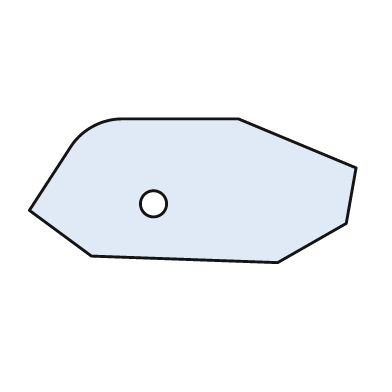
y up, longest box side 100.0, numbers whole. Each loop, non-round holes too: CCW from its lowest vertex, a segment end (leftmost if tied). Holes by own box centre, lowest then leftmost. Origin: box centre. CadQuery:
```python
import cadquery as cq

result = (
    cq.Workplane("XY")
    .moveTo(26.0, -22.0)
    .lineTo(47.0, -10.0)
    .lineTo(50.0, 7.0)
    .lineTo(14.0, 22.0)
    .lineTo(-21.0, 22.0)
    .threePointArc((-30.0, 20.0), (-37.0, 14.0))
    .lineTo(-50.0, -6.0)
    .lineTo(-31.0, -20.0)
    .close()
    .moveTo(-12.0, -4.0)
    .circle(4.0)
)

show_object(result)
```